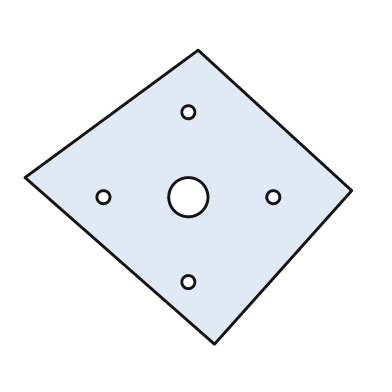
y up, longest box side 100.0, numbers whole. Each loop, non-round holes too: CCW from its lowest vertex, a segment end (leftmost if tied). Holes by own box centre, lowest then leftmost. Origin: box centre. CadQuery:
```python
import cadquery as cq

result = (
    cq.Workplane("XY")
    .moveTo(8.0, -45.0)
    .lineTo(50.0, 2.0)
    .lineTo(3.0, 45.0)
    .lineTo(-50.0, 6.0)
    .close()
    .moveTo(0.0, -26.0)
    .circle(2.0)
    .moveTo(-26.0, 0.0)
    .circle(2.0)
    .moveTo(0.0, 0.0)
    .circle(6.0)
    .moveTo(26.0, 0.0)
    .circle(2.0)
    .moveTo(0.0, 26.0)
    .circle(2.0)
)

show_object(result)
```